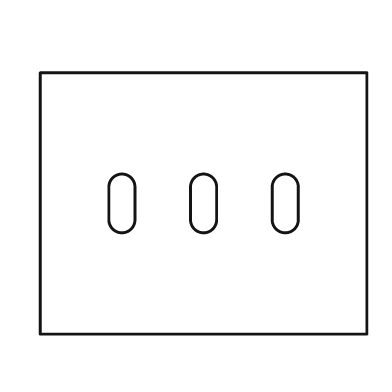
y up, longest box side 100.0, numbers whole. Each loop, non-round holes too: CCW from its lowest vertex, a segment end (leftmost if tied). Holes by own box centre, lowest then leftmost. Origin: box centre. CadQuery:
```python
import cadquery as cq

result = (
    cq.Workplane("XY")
    .moveTo(-50.0, -40.0)
    .lineTo(50.0, -40.0)
    .lineTo(50.0, 40.0)
    .lineTo(-50.0, 40.0)
    .close()
    .moveTo(-29.0, -5.0)
    .threePointArc((-25.0, -9.0), (-21.0, -5.0))
    .lineTo(-21.0, 5.0)
    .threePointArc((-25.0, 9.0), (-29.0, 5.0))
    .close()
    .moveTo(-4.0, -5.0)
    .threePointArc((0.0, -9.0), (4.0, -5.0))
    .lineTo(4.0, 5.0)
    .threePointArc((0.0, 9.0), (-4.0, 5.0))
    .close()
    .moveTo(21.0, -5.0)
    .threePointArc((25.0, -9.0), (29.0, -5.0))
    .lineTo(29.0, 5.0)
    .threePointArc((25.0, 9.0), (21.0, 5.0))
    .close()
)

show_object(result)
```